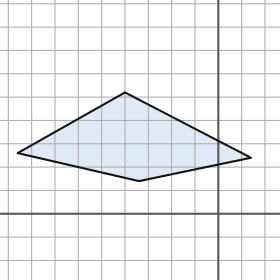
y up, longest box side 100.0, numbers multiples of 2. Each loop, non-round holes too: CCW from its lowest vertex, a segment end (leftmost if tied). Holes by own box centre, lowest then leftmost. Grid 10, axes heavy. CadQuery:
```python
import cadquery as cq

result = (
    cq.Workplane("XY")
    .moveTo(-34.0, 14.0)
    .lineTo(14.0, 24.0)
    .lineTo(-40.0, 52.0)
    .lineTo(-86.0, 26.0)
    .close()
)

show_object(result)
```